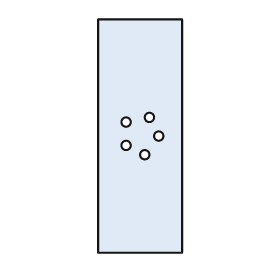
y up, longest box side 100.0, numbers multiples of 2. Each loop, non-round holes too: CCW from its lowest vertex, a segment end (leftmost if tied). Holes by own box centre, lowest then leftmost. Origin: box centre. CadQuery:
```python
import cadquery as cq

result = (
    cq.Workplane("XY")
    .moveTo(-18.0, -50.0)
    .lineTo(18.0, -50.0)
    .lineTo(18.0, 50.0)
    .lineTo(-18.0, 50.0)
    .close()
    .moveTo(2.0, -8.0)
    .circle(2.0)
    .moveTo(-6.0, -4.0)
    .circle(2.0)
    .moveTo(8.0, 0.0)
    .circle(2.0)
    .moveTo(-6.0, 6.0)
    .circle(2.0)
    .moveTo(4.0, 8.0)
    .circle(2.0)
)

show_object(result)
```